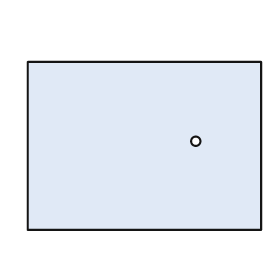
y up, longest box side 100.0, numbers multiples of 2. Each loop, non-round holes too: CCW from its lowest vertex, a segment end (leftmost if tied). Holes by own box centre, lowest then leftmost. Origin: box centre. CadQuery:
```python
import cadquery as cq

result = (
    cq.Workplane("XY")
    .moveTo(-50.0, -36.0)
    .lineTo(50.0, -36.0)
    .lineTo(50.0, 36.0)
    .lineTo(-50.0, 36.0)
    .close()
    .moveTo(22.0, 2.0)
    .circle(2.0)
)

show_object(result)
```